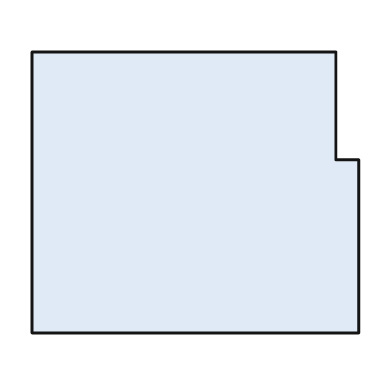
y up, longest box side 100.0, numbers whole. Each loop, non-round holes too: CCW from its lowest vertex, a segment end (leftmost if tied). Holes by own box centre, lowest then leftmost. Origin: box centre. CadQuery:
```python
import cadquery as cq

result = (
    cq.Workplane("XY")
    .moveTo(-50.0, -43.0)
    .lineTo(50.0, -43.0)
    .lineTo(50.0, 10.0)
    .lineTo(43.0, 10.0)
    .lineTo(43.0, 43.0)
    .lineTo(-50.0, 43.0)
    .close()
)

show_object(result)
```